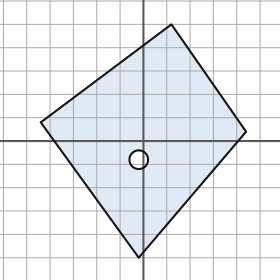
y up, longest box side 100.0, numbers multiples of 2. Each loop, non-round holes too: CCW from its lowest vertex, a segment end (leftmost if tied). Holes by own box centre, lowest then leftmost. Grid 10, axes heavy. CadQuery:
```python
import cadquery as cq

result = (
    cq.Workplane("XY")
    .moveTo(-2.0, -50.0)
    .lineTo(44.0, 4.0)
    .lineTo(12.0, 50.0)
    .lineTo(-44.0, 8.0)
    .close()
    .moveTo(-2.0, -8.0)
    .circle(4.0)
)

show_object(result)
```